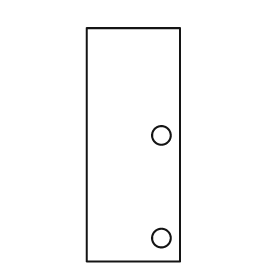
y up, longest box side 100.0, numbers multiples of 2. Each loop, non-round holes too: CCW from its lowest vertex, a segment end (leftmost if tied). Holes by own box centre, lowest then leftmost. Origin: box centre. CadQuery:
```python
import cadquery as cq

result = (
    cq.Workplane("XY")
    .moveTo(-20.0, -50.0)
    .lineTo(20.0, -50.0)
    .lineTo(20.0, 50.0)
    .lineTo(-20.0, 50.0)
    .close()
    .moveTo(12.0, -40.0)
    .circle(4.0)
    .moveTo(12.0, 4.0)
    .circle(4.0)
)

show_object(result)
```